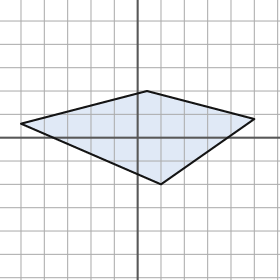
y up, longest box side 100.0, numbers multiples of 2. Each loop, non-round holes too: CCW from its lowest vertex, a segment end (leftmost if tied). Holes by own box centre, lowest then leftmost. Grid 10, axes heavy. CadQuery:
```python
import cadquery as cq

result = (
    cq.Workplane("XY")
    .moveTo(10.0, -20.0)
    .lineTo(50.0, 8.0)
    .lineTo(4.0, 20.0)
    .lineTo(-50.0, 6.0)
    .close()
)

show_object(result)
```